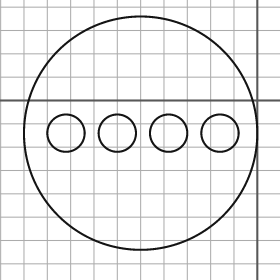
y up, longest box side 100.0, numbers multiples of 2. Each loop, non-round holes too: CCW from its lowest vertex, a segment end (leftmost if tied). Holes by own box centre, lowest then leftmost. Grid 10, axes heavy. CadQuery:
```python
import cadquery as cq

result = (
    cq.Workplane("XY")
    .moveTo(-50.0, -14.0)
    .circle(50.0)
    .moveTo(-82.0, -14.0)
    .circle(8.0)
    .moveTo(-60.0, -14.0)
    .circle(8.0)
    .moveTo(-38.0, -14.0)
    .circle(8.0)
    .moveTo(-16.0, -14.0)
    .circle(8.0)
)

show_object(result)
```